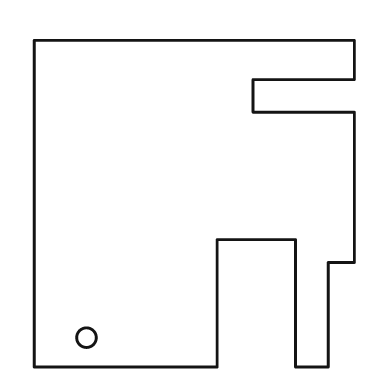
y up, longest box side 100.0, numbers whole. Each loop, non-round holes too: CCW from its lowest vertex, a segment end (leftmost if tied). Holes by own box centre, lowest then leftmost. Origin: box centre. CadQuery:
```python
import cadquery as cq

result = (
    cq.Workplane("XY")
    .moveTo(-49.0, -50.0)
    .lineTo(7.0, -50.0)
    .lineTo(7.0, -11.0)
    .lineTo(31.0, -11.0)
    .lineTo(31.0, -50.0)
    .lineTo(41.0, -50.0)
    .lineTo(41.0, -18.0)
    .lineTo(49.0, -18.0)
    .lineTo(49.0, 28.0)
    .lineTo(18.0, 28.0)
    .lineTo(18.0, 38.0)
    .lineTo(49.0, 38.0)
    .lineTo(49.0, 50.0)
    .lineTo(-49.0, 50.0)
    .close()
    .moveTo(-33.0, -41.0)
    .circle(3.0)
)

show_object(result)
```